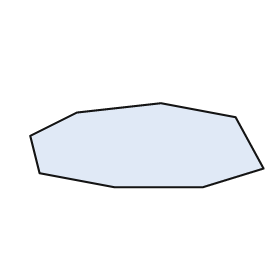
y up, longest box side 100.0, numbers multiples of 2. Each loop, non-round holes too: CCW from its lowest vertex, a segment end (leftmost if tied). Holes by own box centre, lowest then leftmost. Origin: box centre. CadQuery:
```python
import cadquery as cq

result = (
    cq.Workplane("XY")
    .moveTo(-14.0, -18.0)
    .lineTo(24.0, -18.0)
    .lineTo(50.0, -10.0)
    .lineTo(38.0, 12.0)
    .lineTo(6.0, 18.0)
    .lineTo(-30.0, 14.0)
    .lineTo(-50.0, 4.0)
    .lineTo(-46.0, -12.0)
    .close()
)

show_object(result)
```